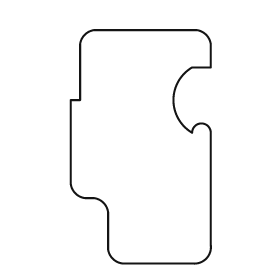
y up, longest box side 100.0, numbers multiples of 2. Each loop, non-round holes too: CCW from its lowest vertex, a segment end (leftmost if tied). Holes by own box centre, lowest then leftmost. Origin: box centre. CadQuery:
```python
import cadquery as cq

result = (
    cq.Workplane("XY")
    .moveTo(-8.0, -50.0)
    .lineTo(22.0, -50.0)
    .threePointArc((28.0, -48.0), (30.0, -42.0))
    .lineTo(30.0, 6.0)
    .threePointArc((26.0, 10.0), (22.0, 6.0))
    .threePointArc((14.0, 20.0), (22.0, 34.0))
    .lineTo(30.0, 34.0)
    .lineTo(30.0, 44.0)
    .threePointArc((28.0, 48.0), (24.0, 50.0))
    .lineTo(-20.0, 50.0)
    .threePointArc((-24.0, 48.0), (-26.0, 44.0))
    .lineTo(-26.0, 20.0)
    .lineTo(-30.0, 20.0)
    .lineTo(-30.0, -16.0)
    .threePointArc((-28.0, -20.0), (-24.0, -22.0))
    .lineTo(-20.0, -22.0)
    .threePointArc((-16.0, -24.0), (-14.0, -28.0))
    .lineTo(-14.0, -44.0)
    .threePointArc((-12.0, -48.0), (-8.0, -50.0))
    .close()
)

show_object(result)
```